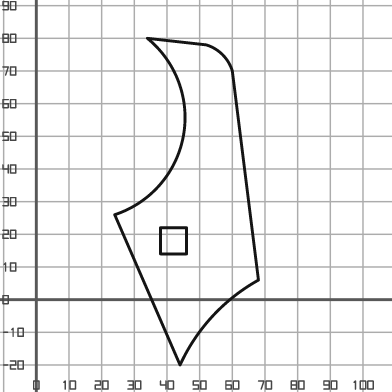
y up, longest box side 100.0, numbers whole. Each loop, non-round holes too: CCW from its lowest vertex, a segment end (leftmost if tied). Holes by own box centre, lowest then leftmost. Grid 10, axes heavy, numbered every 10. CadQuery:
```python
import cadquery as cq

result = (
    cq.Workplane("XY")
    .moveTo(44.0, -20.0)
    .threePointArc((54.0, -5.0), (68.0, 6.0))
    .lineTo(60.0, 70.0)
    .threePointArc((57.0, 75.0), (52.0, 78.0))
    .lineTo(34.0, 80.0)
    .threePointArc((45.0, 50.0), (24.0, 26.0))
    .close()
    .moveTo(38.0, 14.0)
    .lineTo(46.0, 14.0)
    .lineTo(46.0, 22.0)
    .lineTo(38.0, 22.0)
    .close()
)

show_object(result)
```